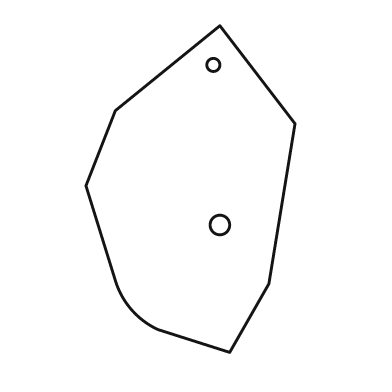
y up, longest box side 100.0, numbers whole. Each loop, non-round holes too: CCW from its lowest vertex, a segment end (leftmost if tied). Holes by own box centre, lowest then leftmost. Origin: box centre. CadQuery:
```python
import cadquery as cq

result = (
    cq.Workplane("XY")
    .moveTo(12.0, -50.0)
    .lineTo(24.0, -29.0)
    .lineTo(32.0, 20.0)
    .lineTo(9.0, 50.0)
    .lineTo(-23.0, 24.0)
    .lineTo(-32.0, 1.0)
    .lineTo(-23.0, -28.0)
    .threePointArc((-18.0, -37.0), (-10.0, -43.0))
    .close()
    .moveTo(9.0, -11.0)
    .circle(3.0)
    .moveTo(7.0, 38.0)
    .circle(2.0)
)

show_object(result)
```